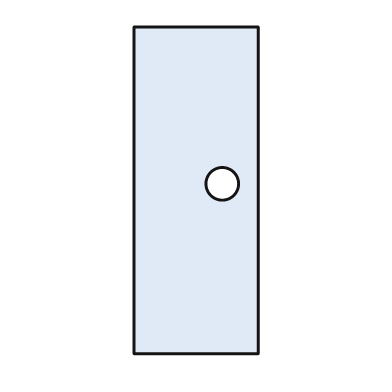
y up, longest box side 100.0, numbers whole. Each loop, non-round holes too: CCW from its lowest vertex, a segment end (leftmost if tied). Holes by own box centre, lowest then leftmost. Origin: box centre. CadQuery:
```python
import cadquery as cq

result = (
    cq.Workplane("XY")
    .moveTo(-19.0, -50.0)
    .lineTo(19.0, -50.0)
    .lineTo(19.0, 50.0)
    .lineTo(-19.0, 50.0)
    .close()
    .moveTo(8.0, 2.0)
    .circle(5.0)
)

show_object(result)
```